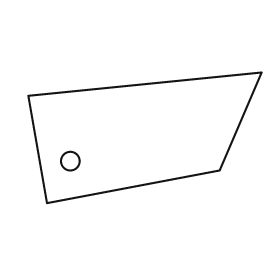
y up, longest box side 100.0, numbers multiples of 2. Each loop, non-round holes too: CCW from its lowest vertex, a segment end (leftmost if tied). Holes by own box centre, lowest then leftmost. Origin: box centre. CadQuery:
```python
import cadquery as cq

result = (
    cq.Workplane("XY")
    .moveTo(-42.0, -28.0)
    .lineTo(32.0, -14.0)
    .lineTo(50.0, 28.0)
    .lineTo(-50.0, 18.0)
    .close()
    .moveTo(-32.0, -10.0)
    .circle(4.0)
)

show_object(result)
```